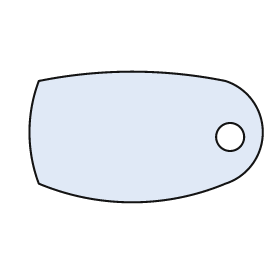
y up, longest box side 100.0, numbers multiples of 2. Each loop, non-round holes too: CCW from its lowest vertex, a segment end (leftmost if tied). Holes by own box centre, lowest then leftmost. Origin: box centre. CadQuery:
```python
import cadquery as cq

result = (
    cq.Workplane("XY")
    .moveTo(-46.0, -20.0)
    .threePointArc((-6.0, -28.0), (34.0, -20.0))
    .threePointArc((50.0, 2.0), (34.0, 24.0))
    .threePointArc((-6.0, 28.0), (-46.0, 24.0))
    .threePointArc((-50.0, 2.0), (-46.0, -20.0))
    .close()
    .moveTo(36.0, 0.0)
    .circle(6.0)
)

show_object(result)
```